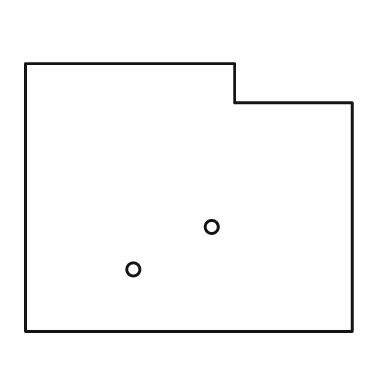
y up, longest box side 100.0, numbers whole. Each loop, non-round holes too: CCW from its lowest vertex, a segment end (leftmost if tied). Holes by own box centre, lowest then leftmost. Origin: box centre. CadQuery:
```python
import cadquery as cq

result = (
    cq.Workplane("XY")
    .moveTo(-50.0, -41.0)
    .lineTo(50.0, -41.0)
    .lineTo(50.0, 29.0)
    .lineTo(14.0, 29.0)
    .lineTo(14.0, 41.0)
    .lineTo(-50.0, 41.0)
    .close()
    .moveTo(-17.0, -22.0)
    .circle(2.0)
    .moveTo(7.0, -9.0)
    .circle(2.0)
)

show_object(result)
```